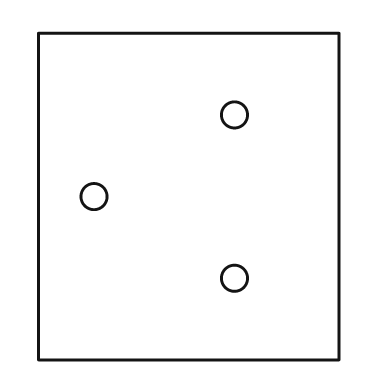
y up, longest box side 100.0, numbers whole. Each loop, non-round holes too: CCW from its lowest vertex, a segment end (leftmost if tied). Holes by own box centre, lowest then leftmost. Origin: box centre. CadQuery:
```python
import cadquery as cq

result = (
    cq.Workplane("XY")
    .moveTo(-46.0, -50.0)
    .lineTo(46.0, -50.0)
    .lineTo(46.0, 50.0)
    .lineTo(-46.0, 50.0)
    .close()
    .moveTo(14.0, -25.0)
    .circle(4.0)
    .moveTo(-29.0, 0.0)
    .circle(4.0)
    .moveTo(14.0, 25.0)
    .circle(4.0)
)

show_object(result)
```